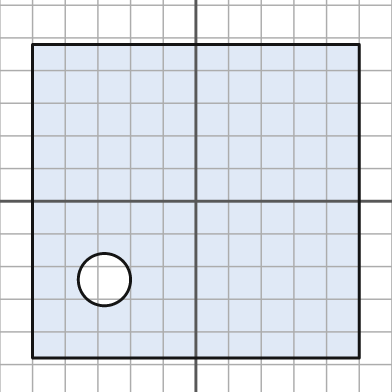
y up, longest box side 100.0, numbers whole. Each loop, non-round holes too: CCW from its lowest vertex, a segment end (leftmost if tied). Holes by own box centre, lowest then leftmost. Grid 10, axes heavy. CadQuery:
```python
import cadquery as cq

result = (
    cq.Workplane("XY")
    .moveTo(-50.0, -48.0)
    .lineTo(50.0, -48.0)
    .lineTo(50.0, 48.0)
    .lineTo(-50.0, 48.0)
    .close()
    .moveTo(-28.0, -24.0)
    .circle(8.0)
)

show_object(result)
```